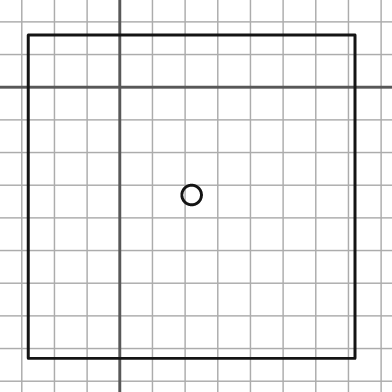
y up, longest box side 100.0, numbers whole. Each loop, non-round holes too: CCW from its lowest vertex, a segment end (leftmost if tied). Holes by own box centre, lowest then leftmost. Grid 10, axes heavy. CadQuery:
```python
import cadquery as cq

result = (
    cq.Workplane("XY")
    .moveTo(-28.0, -83.0)
    .lineTo(72.0, -83.0)
    .lineTo(72.0, 16.0)
    .lineTo(-28.0, 16.0)
    .close()
    .moveTo(22.0, -33.0)
    .circle(3.0)
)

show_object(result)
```